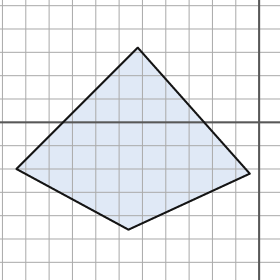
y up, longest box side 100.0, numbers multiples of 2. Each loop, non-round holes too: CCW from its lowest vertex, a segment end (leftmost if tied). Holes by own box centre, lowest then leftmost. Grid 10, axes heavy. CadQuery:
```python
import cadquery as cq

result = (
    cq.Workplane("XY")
    .moveTo(-56.0, -46.0)
    .lineTo(-4.0, -22.0)
    .lineTo(-52.0, 32.0)
    .lineTo(-104.0, -20.0)
    .close()
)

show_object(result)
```